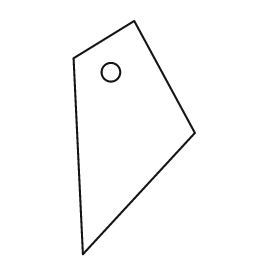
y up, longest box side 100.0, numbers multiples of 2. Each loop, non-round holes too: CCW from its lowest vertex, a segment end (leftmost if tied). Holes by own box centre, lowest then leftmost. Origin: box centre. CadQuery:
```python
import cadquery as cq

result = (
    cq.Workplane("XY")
    .moveTo(-22.0, -50.0)
    .lineTo(26.0, 2.0)
    .lineTo(0.0, 50.0)
    .lineTo(-26.0, 34.0)
    .close()
    .moveTo(-10.0, 28.0)
    .circle(4.0)
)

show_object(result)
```